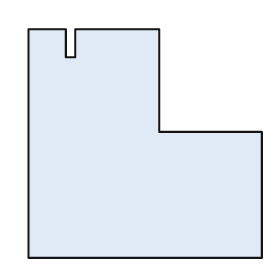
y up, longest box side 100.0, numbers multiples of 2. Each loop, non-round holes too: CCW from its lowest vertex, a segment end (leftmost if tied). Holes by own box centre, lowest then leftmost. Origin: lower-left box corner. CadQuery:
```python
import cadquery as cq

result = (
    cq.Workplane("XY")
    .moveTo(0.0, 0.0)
    .lineTo(100.0, 0.0)
    .lineTo(100.0, 54.0)
    .lineTo(56.0, 54.0)
    .lineTo(56.0, 98.0)
    .lineTo(20.0, 98.0)
    .lineTo(20.0, 86.0)
    .lineTo(16.0, 86.0)
    .lineTo(16.0, 98.0)
    .lineTo(0.0, 98.0)
    .close()
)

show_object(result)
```